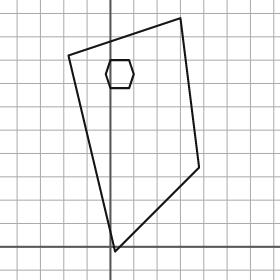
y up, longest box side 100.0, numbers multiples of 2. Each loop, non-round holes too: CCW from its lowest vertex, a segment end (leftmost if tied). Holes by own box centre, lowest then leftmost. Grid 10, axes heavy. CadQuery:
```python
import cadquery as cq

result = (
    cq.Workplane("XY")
    .moveTo(2.0, -2.0)
    .lineTo(38.0, 34.0)
    .lineTo(30.0, 98.0)
    .lineTo(-18.0, 82.0)
    .close()
    .moveTo(0.0, 68.0)
    .lineTo(8.0, 68.0)
    .lineTo(10.0, 74.0)
    .lineTo(8.0, 80.0)
    .lineTo(0.0, 80.0)
    .lineTo(-2.0, 74.0)
    .close()
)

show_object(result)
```